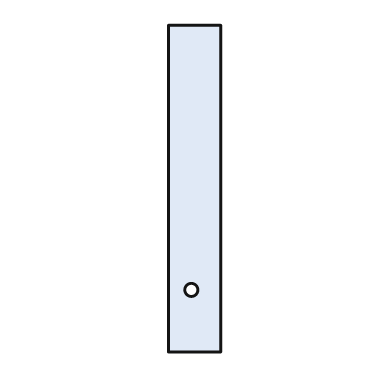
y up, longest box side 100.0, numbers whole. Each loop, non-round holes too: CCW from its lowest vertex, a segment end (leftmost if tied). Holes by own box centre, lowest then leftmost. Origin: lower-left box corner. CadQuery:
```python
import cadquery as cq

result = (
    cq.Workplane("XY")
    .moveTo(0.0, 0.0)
    .lineTo(16.0, 0.0)
    .lineTo(16.0, 100.0)
    .lineTo(0.0, 100.0)
    .close()
    .moveTo(7.0, 19.0)
    .circle(2.0)
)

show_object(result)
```